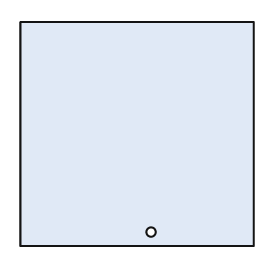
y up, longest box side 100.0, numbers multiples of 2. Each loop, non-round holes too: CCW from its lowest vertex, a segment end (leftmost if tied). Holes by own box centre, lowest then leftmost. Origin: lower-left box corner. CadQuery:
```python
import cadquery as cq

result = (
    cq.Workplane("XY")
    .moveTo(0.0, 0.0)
    .lineTo(100.0, 0.0)
    .lineTo(100.0, 96.0)
    .lineTo(0.0, 96.0)
    .close()
    .moveTo(56.0, 6.0)
    .circle(2.0)
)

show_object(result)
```